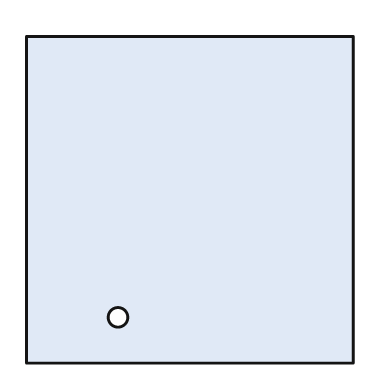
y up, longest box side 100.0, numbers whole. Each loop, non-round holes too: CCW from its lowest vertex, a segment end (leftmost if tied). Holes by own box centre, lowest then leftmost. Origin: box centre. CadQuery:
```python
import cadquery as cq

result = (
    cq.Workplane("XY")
    .moveTo(-50.0, -50.0)
    .lineTo(50.0, -50.0)
    .lineTo(50.0, 50.0)
    .lineTo(-50.0, 50.0)
    .close()
    .moveTo(-22.0, -36.0)
    .circle(3.0)
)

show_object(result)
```